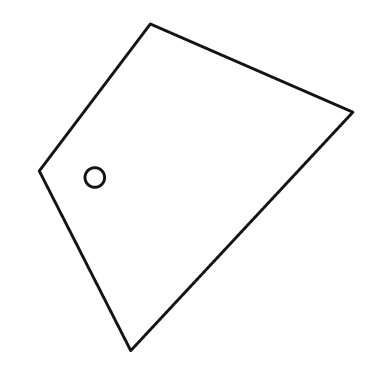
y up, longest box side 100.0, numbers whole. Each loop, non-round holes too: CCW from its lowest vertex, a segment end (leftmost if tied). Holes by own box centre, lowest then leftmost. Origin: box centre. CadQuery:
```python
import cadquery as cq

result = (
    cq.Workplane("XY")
    .moveTo(-20.0, -50.0)
    .lineTo(48.0, 23.0)
    .lineTo(-14.0, 50.0)
    .lineTo(-48.0, 5.0)
    .close()
    .moveTo(-31.0, 3.0)
    .circle(3.0)
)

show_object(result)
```